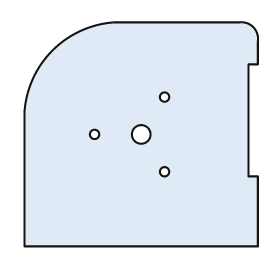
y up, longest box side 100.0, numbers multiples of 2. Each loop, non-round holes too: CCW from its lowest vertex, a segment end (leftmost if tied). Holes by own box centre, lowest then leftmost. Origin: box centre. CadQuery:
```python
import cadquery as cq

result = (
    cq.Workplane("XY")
    .moveTo(-50.0, -48.0)
    .lineTo(50.0, -48.0)
    .lineTo(50.0, -18.0)
    .lineTo(46.0, -18.0)
    .lineTo(46.0, 30.0)
    .lineTo(50.0, 30.0)
    .lineTo(50.0, 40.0)
    .threePointArc((48.0, 46.0), (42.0, 48.0))
    .lineTo(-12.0, 48.0)
    .threePointArc((-38.0, 36.0), (-50.0, 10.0))
    .close()
    .moveTo(10.0, -16.0)
    .circle(2.0)
    .moveTo(-20.0, 0.0)
    .circle(2.0)
    .moveTo(0.0, 0.0)
    .circle(4.0)
    .moveTo(10.0, 16.0)
    .circle(2.0)
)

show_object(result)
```